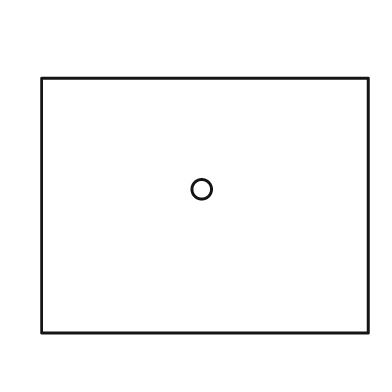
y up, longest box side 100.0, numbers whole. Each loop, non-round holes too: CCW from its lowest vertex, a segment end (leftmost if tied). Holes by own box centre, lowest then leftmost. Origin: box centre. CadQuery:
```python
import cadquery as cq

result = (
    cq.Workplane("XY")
    .moveTo(-50.0, -39.0)
    .lineTo(50.0, -39.0)
    .lineTo(50.0, 39.0)
    .lineTo(-50.0, 39.0)
    .close()
    .moveTo(-1.0, 5.0)
    .circle(3.0)
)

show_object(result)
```